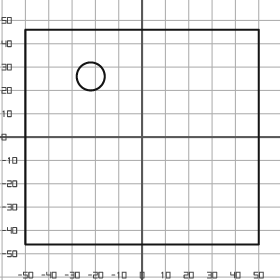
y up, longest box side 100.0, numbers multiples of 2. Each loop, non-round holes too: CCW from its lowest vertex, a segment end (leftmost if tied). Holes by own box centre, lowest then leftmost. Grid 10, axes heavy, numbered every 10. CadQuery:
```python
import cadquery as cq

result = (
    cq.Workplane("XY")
    .moveTo(-50.0, -46.0)
    .lineTo(50.0, -46.0)
    .lineTo(50.0, 46.0)
    .lineTo(-50.0, 46.0)
    .close()
    .moveTo(-22.0, 26.0)
    .circle(6.0)
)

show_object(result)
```